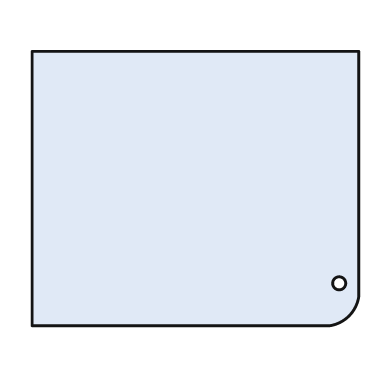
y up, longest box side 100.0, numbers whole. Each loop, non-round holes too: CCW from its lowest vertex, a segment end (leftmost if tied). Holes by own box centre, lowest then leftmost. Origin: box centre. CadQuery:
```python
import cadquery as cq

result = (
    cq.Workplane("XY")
    .moveTo(-50.0, -42.0)
    .lineTo(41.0, -42.0)
    .threePointArc((47.0, -39.0), (50.0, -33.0))
    .lineTo(50.0, 42.0)
    .lineTo(-50.0, 42.0)
    .close()
    .moveTo(44.0, -29.0)
    .circle(2.0)
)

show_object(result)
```